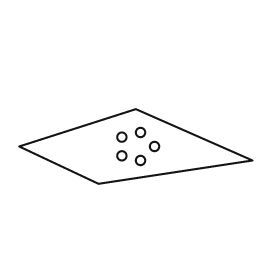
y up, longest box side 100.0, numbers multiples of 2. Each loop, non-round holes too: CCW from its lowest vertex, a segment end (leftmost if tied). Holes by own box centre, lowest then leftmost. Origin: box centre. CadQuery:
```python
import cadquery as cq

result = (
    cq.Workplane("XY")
    .moveTo(-16.0, -16.0)
    .lineTo(50.0, -6.0)
    .lineTo(0.0, 16.0)
    .lineTo(-50.0, 0.0)
    .close()
    .moveTo(2.0, -6.0)
    .circle(2.0)
    .moveTo(-6.0, -4.0)
    .circle(2.0)
    .moveTo(8.0, 0.0)
    .circle(2.0)
    .moveTo(-6.0, 4.0)
    .circle(2.0)
    .moveTo(2.0, 6.0)
    .circle(2.0)
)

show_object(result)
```